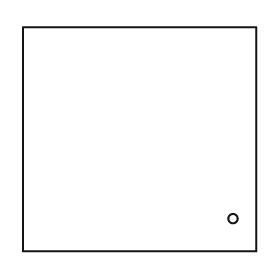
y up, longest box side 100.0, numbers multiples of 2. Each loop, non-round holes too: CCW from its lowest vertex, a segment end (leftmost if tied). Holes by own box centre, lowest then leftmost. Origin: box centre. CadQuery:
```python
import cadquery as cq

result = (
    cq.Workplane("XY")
    .moveTo(-50.0, -48.0)
    .lineTo(50.0, -48.0)
    .lineTo(50.0, 48.0)
    .lineTo(-50.0, 48.0)
    .close()
    .moveTo(40.0, -34.0)
    .circle(2.0)
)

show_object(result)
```